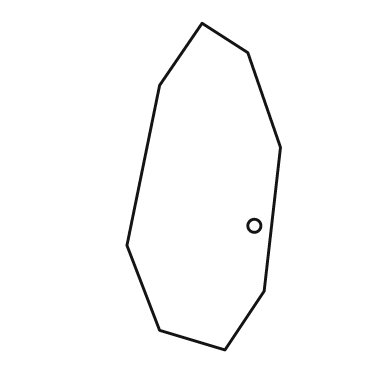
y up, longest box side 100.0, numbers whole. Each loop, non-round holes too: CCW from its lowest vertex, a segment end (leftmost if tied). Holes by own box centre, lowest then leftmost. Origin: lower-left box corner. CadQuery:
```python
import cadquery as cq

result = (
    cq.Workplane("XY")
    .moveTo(30.0, 0.0)
    .lineTo(42.0, 18.0)
    .lineTo(47.0, 62.0)
    .lineTo(37.0, 91.0)
    .lineTo(23.0, 100.0)
    .lineTo(10.0, 81.0)
    .lineTo(0.0, 32.0)
    .lineTo(10.0, 6.0)
    .close()
    .moveTo(39.0, 38.0)
    .circle(2.0)
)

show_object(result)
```